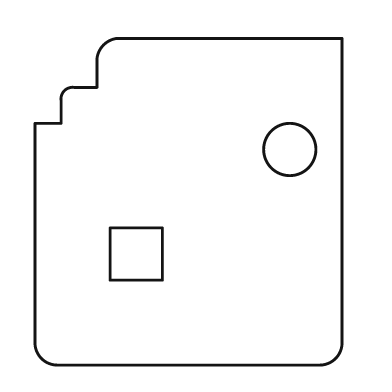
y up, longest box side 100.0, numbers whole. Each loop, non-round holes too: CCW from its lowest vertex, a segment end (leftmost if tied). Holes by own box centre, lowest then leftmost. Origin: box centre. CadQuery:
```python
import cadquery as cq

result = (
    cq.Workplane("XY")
    .moveTo(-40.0, -50.0)
    .lineTo(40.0, -50.0)
    .threePointArc((45.0, -48.0), (47.0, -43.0))
    .lineTo(47.0, 50.0)
    .lineTo(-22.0, 50.0)
    .threePointArc((-26.0, 48.0), (-28.0, 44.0))
    .lineTo(-28.0, 35.0)
    .lineTo(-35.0, 35.0)
    .threePointArc((-38.0, 34.0), (-39.0, 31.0))
    .lineTo(-39.0, 24.0)
    .lineTo(-47.0, 24.0)
    .lineTo(-47.0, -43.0)
    .threePointArc((-45.0, -48.0), (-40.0, -50.0))
    .close()
    .moveTo(-24.0, -24.0)
    .lineTo(-8.0, -24.0)
    .lineTo(-8.0, -8.0)
    .lineTo(-24.0, -8.0)
    .close()
    .moveTo(31.0, 16.0)
    .circle(8.0)
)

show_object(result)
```